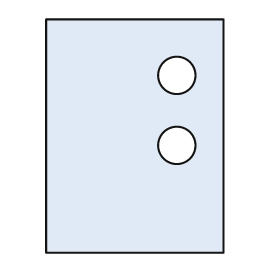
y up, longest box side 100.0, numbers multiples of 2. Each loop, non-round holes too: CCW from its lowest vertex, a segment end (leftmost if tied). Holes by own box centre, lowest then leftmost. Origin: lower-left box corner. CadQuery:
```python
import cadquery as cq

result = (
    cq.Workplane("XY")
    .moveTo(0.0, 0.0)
    .lineTo(76.0, 0.0)
    .lineTo(76.0, 100.0)
    .lineTo(0.0, 100.0)
    .close()
    .moveTo(56.0, 46.0)
    .circle(8.0)
    .moveTo(56.0, 76.0)
    .circle(8.0)
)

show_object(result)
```